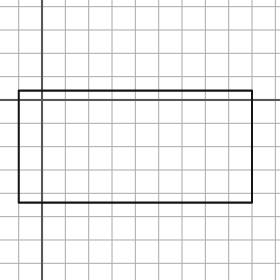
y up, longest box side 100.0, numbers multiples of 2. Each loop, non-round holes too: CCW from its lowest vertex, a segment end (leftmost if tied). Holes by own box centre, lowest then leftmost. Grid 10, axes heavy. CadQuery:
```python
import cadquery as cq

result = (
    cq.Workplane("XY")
    .moveTo(-10.0, -44.0)
    .lineTo(90.0, -44.0)
    .lineTo(90.0, 4.0)
    .lineTo(-10.0, 4.0)
    .close()
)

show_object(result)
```